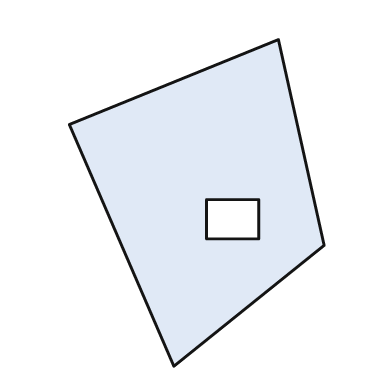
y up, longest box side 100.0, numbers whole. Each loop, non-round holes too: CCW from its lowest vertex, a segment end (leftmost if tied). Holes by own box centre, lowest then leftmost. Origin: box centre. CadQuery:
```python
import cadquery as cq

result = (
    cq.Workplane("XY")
    .moveTo(-7.0, -50.0)
    .lineTo(39.0, -13.0)
    .lineTo(25.0, 50.0)
    .lineTo(-39.0, 24.0)
    .close()
    .moveTo(3.0, -11.0)
    .lineTo(19.0, -11.0)
    .lineTo(19.0, 1.0)
    .lineTo(3.0, 1.0)
    .close()
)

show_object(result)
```